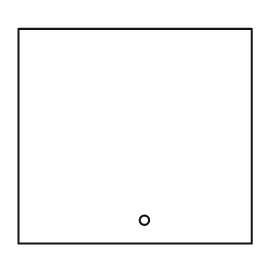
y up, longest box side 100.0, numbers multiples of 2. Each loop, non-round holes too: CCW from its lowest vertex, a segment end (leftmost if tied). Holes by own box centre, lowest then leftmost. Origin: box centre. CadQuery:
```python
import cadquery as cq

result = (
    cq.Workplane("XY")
    .moveTo(-50.0, -46.0)
    .lineTo(50.0, -46.0)
    .lineTo(50.0, 46.0)
    .lineTo(-50.0, 46.0)
    .close()
    .moveTo(4.0, -36.0)
    .circle(2.0)
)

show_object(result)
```